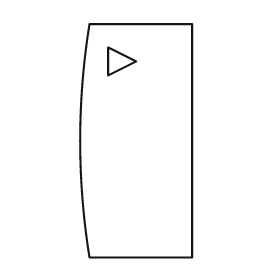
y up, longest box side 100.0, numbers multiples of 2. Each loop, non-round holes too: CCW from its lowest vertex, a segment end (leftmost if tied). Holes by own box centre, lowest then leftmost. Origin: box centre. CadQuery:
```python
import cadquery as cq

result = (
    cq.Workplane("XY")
    .moveTo(-20.0, -50.0)
    .lineTo(24.0, -50.0)
    .lineTo(24.0, 50.0)
    .lineTo(-20.0, 50.0)
    .threePointArc((-24.0, 0.0), (-20.0, -50.0))
    .close()
    .moveTo(-12.0, 28.0)
    .lineTo(0.0, 34.0)
    .lineTo(-12.0, 40.0)
    .close()
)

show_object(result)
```